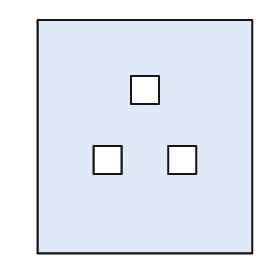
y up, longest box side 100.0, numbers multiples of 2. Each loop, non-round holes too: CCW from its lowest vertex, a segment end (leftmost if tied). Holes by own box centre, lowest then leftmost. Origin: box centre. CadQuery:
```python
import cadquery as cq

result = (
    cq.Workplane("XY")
    .moveTo(-46.0, -50.0)
    .lineTo(46.0, -50.0)
    .lineTo(46.0, 50.0)
    .lineTo(-46.0, 50.0)
    .close()
    .moveTo(-22.0, -16.0)
    .lineTo(-10.0, -16.0)
    .lineTo(-10.0, -4.0)
    .lineTo(-22.0, -4.0)
    .close()
    .moveTo(10.0, -16.0)
    .lineTo(22.0, -16.0)
    .lineTo(22.0, -4.0)
    .lineTo(10.0, -4.0)
    .close()
    .moveTo(-6.0, 14.0)
    .lineTo(6.0, 14.0)
    .lineTo(6.0, 26.0)
    .lineTo(-6.0, 26.0)
    .close()
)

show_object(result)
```